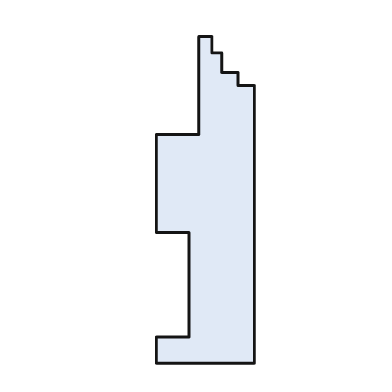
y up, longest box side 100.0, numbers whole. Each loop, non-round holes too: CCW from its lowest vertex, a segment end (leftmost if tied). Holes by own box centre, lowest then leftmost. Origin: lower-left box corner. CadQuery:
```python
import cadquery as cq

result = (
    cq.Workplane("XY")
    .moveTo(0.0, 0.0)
    .lineTo(30.0, 0.0)
    .lineTo(30.0, 85.0)
    .lineTo(25.0, 85.0)
    .lineTo(25.0, 89.0)
    .lineTo(20.0, 89.0)
    .lineTo(20.0, 95.0)
    .lineTo(17.0, 95.0)
    .lineTo(17.0, 100.0)
    .lineTo(13.0, 100.0)
    .lineTo(13.0, 70.0)
    .lineTo(0.0, 70.0)
    .lineTo(0.0, 40.0)
    .lineTo(10.0, 40.0)
    .lineTo(10.0, 8.0)
    .lineTo(0.0, 8.0)
    .close()
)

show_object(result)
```